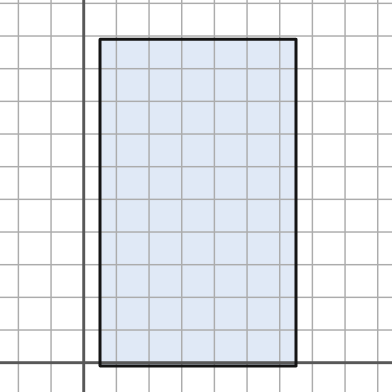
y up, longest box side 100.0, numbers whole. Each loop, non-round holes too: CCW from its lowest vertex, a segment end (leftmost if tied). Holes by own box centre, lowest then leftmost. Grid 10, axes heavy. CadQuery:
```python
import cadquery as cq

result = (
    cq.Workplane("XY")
    .moveTo(5.0, -1.0)
    .lineTo(65.0, -1.0)
    .lineTo(65.0, 99.0)
    .lineTo(5.0, 99.0)
    .close()
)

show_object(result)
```